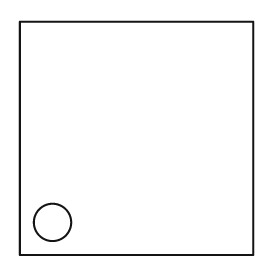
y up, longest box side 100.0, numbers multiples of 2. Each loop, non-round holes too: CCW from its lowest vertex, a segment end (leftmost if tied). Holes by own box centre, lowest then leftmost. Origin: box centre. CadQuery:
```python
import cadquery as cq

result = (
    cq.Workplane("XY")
    .moveTo(-50.0, -50.0)
    .lineTo(50.0, -50.0)
    .lineTo(50.0, 50.0)
    .lineTo(-50.0, 50.0)
    .close()
    .moveTo(-36.0, -36.0)
    .circle(8.0)
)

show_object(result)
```